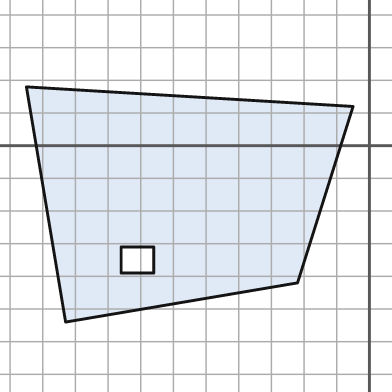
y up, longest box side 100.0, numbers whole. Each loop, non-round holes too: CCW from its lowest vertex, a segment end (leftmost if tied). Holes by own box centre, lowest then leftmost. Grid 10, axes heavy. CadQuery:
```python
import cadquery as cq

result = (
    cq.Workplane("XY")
    .moveTo(-93.0, -54.0)
    .lineTo(-22.0, -42.0)
    .lineTo(-5.0, 12.0)
    .lineTo(-105.0, 18.0)
    .close()
    .moveTo(-76.0, -39.0)
    .lineTo(-66.0, -39.0)
    .lineTo(-66.0, -31.0)
    .lineTo(-76.0, -31.0)
    .close()
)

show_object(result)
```